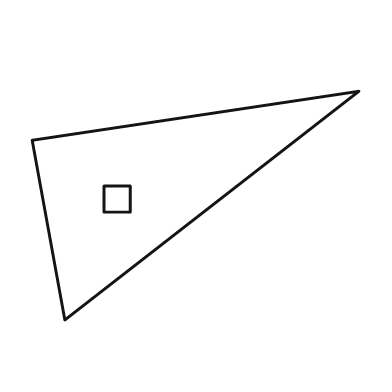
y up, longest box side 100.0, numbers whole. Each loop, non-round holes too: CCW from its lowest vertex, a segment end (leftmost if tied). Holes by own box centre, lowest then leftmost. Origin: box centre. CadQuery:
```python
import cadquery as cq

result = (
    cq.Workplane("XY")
    .moveTo(-40.0, -35.0)
    .lineTo(50.0, 35.0)
    .lineTo(-50.0, 20.0)
    .close()
    .moveTo(-28.0, -2.0)
    .lineTo(-20.0, -2.0)
    .lineTo(-20.0, 6.0)
    .lineTo(-28.0, 6.0)
    .close()
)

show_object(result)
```